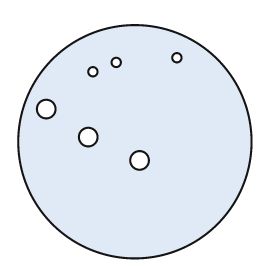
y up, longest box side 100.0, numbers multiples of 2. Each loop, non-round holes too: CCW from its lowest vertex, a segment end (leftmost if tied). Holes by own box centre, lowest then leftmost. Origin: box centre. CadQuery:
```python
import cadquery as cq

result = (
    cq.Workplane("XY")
    .moveTo(0.0, 0.0)
    .circle(50.0)
    .moveTo(2.0, -8.0)
    .circle(4.0)
    .moveTo(-20.0, 2.0)
    .circle(4.0)
    .moveTo(-38.0, 14.0)
    .circle(4.0)
    .moveTo(-18.0, 30.0)
    .circle(2.0)
    .moveTo(-8.0, 34.0)
    .circle(2.0)
    .moveTo(18.0, 36.0)
    .circle(2.0)
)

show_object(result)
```